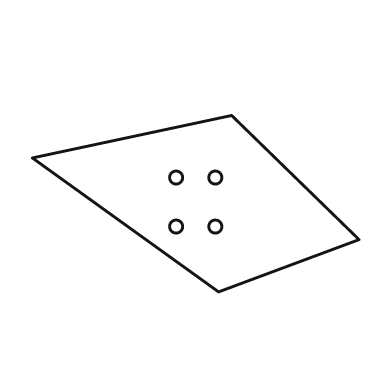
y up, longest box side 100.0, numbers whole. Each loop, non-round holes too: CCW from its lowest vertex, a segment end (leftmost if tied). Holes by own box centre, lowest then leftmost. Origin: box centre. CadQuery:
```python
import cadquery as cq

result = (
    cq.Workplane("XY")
    .moveTo(7.0, -27.0)
    .lineTo(50.0, -11.0)
    .lineTo(11.0, 27.0)
    .lineTo(-50.0, 14.0)
    .close()
    .moveTo(-6.0, -7.0)
    .circle(2.0)
    .moveTo(6.0, -7.0)
    .circle(2.0)
    .moveTo(-6.0, 8.0)
    .circle(2.0)
    .moveTo(6.0, 8.0)
    .circle(2.0)
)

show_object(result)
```